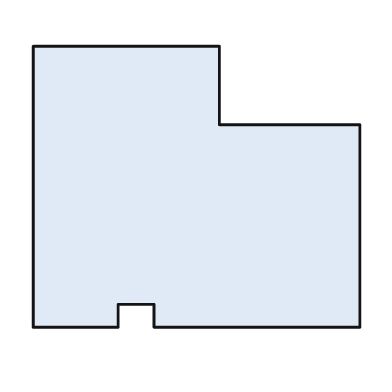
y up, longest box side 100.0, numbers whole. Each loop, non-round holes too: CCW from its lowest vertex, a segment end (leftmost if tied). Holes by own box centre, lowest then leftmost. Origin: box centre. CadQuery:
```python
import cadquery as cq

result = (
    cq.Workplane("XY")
    .moveTo(-50.0, -43.0)
    .lineTo(-24.0, -43.0)
    .lineTo(-24.0, -36.0)
    .lineTo(-13.0, -36.0)
    .lineTo(-13.0, -43.0)
    .lineTo(50.0, -43.0)
    .lineTo(50.0, 19.0)
    .lineTo(7.0, 19.0)
    .lineTo(7.0, 43.0)
    .lineTo(-50.0, 43.0)
    .close()
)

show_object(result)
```